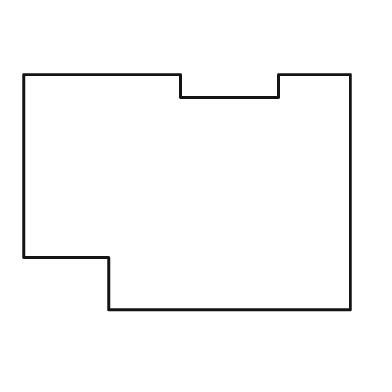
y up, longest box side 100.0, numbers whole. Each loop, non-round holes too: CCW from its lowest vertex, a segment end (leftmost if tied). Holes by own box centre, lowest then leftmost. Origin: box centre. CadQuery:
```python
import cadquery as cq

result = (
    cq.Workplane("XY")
    .moveTo(-24.0, -36.0)
    .lineTo(50.0, -36.0)
    .lineTo(50.0, 36.0)
    .lineTo(28.0, 36.0)
    .lineTo(28.0, 29.0)
    .lineTo(-2.0, 29.0)
    .lineTo(-2.0, 36.0)
    .lineTo(-50.0, 36.0)
    .lineTo(-50.0, -20.0)
    .lineTo(-24.0, -20.0)
    .close()
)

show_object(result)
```